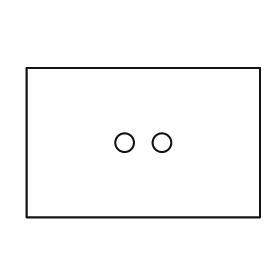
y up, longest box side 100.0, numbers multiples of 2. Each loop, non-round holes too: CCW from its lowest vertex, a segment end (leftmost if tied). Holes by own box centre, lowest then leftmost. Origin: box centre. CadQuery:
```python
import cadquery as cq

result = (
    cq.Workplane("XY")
    .moveTo(-50.0, -32.0)
    .lineTo(50.0, -32.0)
    .lineTo(50.0, 32.0)
    .lineTo(-50.0, 32.0)
    .close()
    .moveTo(-8.0, 0.0)
    .circle(4.0)
    .moveTo(8.0, 0.0)
    .circle(4.0)
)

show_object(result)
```